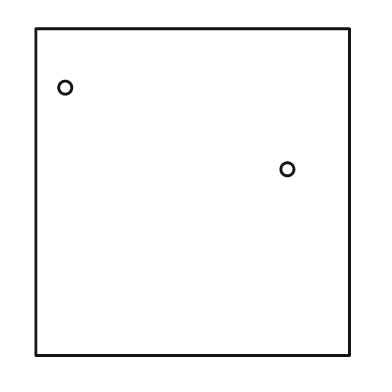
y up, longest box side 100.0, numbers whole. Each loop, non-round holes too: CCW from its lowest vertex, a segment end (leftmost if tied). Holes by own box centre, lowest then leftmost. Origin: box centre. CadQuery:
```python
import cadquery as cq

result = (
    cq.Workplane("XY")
    .moveTo(-48.0, -50.0)
    .lineTo(48.0, -50.0)
    .lineTo(48.0, 50.0)
    .lineTo(-48.0, 50.0)
    .close()
    .moveTo(29.0, 7.0)
    .circle(2.0)
    .moveTo(-39.0, 32.0)
    .circle(2.0)
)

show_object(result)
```